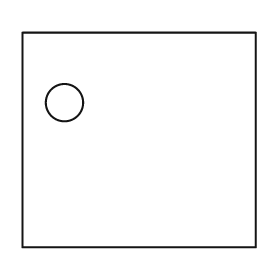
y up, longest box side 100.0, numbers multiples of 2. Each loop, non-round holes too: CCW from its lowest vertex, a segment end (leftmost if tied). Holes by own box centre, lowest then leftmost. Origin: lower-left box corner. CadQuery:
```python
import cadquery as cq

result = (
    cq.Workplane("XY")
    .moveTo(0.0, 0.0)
    .lineTo(100.0, 0.0)
    .lineTo(100.0, 92.0)
    .lineTo(0.0, 92.0)
    .close()
    .moveTo(18.0, 62.0)
    .circle(8.0)
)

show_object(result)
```